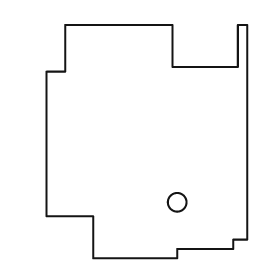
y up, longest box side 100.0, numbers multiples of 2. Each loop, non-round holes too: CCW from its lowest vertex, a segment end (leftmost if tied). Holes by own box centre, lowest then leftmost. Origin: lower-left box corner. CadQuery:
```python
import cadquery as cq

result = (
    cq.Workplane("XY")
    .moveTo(20.0, 0.0)
    .lineTo(56.0, 0.0)
    .lineTo(56.0, 4.0)
    .lineTo(80.0, 4.0)
    .lineTo(80.0, 8.0)
    .lineTo(86.0, 8.0)
    .lineTo(86.0, 100.0)
    .lineTo(82.0, 100.0)
    .lineTo(82.0, 82.0)
    .lineTo(54.0, 82.0)
    .lineTo(54.0, 100.0)
    .lineTo(8.0, 100.0)
    .lineTo(8.0, 80.0)
    .lineTo(0.0, 80.0)
    .lineTo(0.0, 18.0)
    .lineTo(20.0, 18.0)
    .close()
    .moveTo(56.0, 24.0)
    .circle(4.0)
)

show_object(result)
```